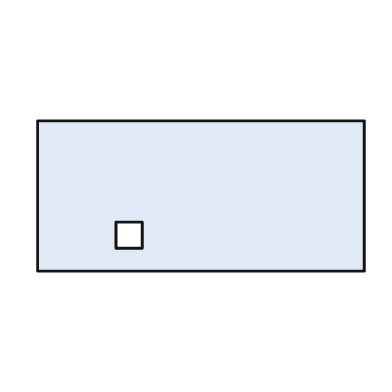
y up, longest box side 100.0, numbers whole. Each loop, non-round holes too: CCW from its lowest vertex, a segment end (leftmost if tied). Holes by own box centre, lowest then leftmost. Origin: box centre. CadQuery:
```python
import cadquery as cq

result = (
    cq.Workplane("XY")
    .moveTo(-50.0, -23.0)
    .lineTo(50.0, -23.0)
    .lineTo(50.0, 23.0)
    .lineTo(-50.0, 23.0)
    .close()
    .moveTo(-26.0, -16.0)
    .lineTo(-18.0, -16.0)
    .lineTo(-18.0, -8.0)
    .lineTo(-26.0, -8.0)
    .close()
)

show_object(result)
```